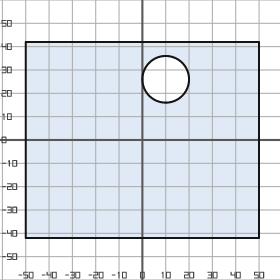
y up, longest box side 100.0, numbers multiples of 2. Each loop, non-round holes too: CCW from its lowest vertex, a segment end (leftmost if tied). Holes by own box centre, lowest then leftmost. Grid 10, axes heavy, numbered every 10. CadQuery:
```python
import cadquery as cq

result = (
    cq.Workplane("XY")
    .moveTo(-50.0, -42.0)
    .lineTo(50.0, -42.0)
    .lineTo(50.0, 42.0)
    .lineTo(-50.0, 42.0)
    .close()
    .moveTo(10.0, 26.0)
    .circle(10.0)
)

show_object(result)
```